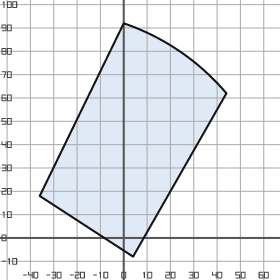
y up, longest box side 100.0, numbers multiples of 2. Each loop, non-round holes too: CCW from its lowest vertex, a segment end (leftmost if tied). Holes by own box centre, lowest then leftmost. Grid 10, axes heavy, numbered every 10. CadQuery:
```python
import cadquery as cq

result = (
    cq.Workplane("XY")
    .moveTo(4.0, -8.0)
    .lineTo(44.0, 62.0)
    .threePointArc((24.0, 80.0), (0.0, 92.0))
    .lineTo(-36.0, 18.0)
    .close()
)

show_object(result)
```